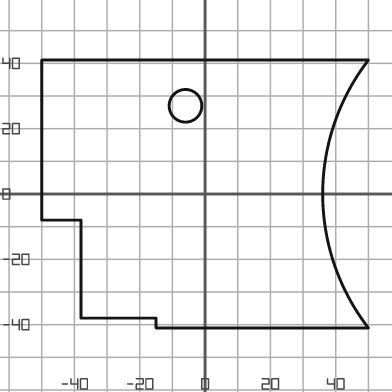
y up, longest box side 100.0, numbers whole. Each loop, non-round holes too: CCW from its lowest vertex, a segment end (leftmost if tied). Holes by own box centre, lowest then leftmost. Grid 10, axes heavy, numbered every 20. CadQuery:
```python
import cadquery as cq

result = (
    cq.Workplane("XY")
    .moveTo(-15.0, -41.0)
    .lineTo(50.0, -41.0)
    .threePointArc((36.0, 0.0), (50.0, 41.0))
    .lineTo(-50.0, 41.0)
    .lineTo(-50.0, -8.0)
    .lineTo(-38.0, -8.0)
    .lineTo(-38.0, -38.0)
    .lineTo(-15.0, -38.0)
    .close()
    .moveTo(-6.0, 27.0)
    .circle(5.0)
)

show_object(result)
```